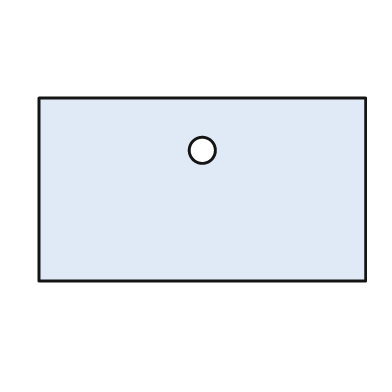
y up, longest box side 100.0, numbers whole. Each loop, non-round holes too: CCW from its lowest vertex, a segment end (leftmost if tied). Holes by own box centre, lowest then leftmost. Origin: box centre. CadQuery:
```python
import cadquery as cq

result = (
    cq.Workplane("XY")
    .moveTo(-50.0, -28.0)
    .lineTo(50.0, -28.0)
    .lineTo(50.0, 28.0)
    .lineTo(-50.0, 28.0)
    .close()
    .moveTo(0.0, 12.0)
    .circle(4.0)
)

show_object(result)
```